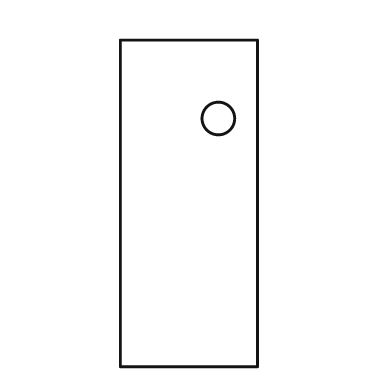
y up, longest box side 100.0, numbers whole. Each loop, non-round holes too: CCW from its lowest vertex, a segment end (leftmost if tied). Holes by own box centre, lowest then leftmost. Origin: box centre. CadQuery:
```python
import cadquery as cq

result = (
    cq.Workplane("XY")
    .moveTo(-21.0, -50.0)
    .lineTo(21.0, -50.0)
    .lineTo(21.0, 50.0)
    .lineTo(-21.0, 50.0)
    .close()
    .moveTo(9.0, 26.0)
    .circle(5.0)
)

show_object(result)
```